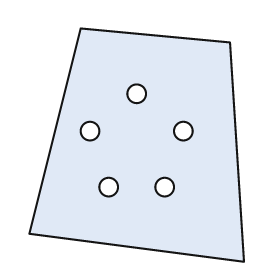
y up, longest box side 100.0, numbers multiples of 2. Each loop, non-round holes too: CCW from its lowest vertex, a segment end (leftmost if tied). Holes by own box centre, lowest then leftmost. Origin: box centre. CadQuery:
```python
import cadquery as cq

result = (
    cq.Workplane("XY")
    .moveTo(46.0, -50.0)
    .lineTo(40.0, 44.0)
    .lineTo(-24.0, 50.0)
    .lineTo(-46.0, -38.0)
    .close()
    .moveTo(-12.0, -18.0)
    .circle(4.0)
    .moveTo(12.0, -18.0)
    .circle(4.0)
    .moveTo(-20.0, 6.0)
    .circle(4.0)
    .moveTo(20.0, 6.0)
    .circle(4.0)
    .moveTo(0.0, 22.0)
    .circle(4.0)
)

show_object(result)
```